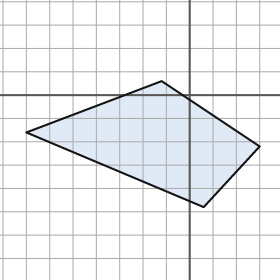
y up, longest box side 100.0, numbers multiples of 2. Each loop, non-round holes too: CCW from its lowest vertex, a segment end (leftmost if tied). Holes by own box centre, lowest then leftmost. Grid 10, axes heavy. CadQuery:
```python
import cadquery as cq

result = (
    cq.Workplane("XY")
    .moveTo(6.0, -48.0)
    .lineTo(30.0, -22.0)
    .lineTo(-12.0, 6.0)
    .lineTo(-70.0, -16.0)
    .close()
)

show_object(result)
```